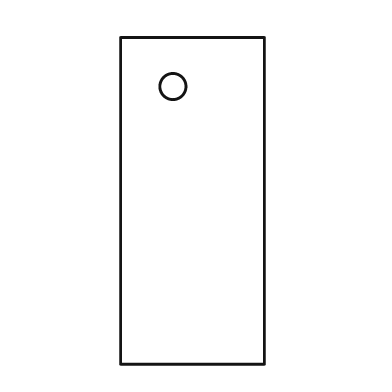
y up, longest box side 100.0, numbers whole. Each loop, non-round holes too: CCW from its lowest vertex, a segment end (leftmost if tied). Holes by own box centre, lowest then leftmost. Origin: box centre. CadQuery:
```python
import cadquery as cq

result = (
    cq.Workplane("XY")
    .moveTo(-22.0, -50.0)
    .lineTo(22.0, -50.0)
    .lineTo(22.0, 50.0)
    .lineTo(-22.0, 50.0)
    .close()
    .moveTo(-6.0, 35.0)
    .circle(4.0)
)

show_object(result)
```